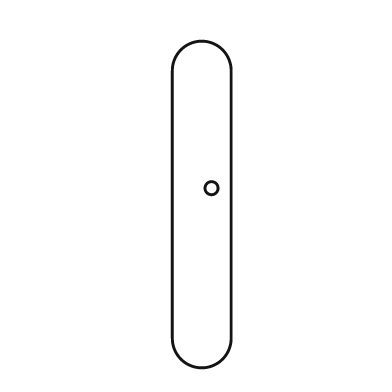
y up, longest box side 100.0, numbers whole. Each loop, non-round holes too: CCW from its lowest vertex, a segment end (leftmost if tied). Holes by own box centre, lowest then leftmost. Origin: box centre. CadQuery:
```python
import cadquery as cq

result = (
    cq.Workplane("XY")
    .moveTo(-9.0, -41.0)
    .threePointArc((0.0, -50.0), (9.0, -41.0))
    .lineTo(9.0, 41.0)
    .threePointArc((0.0, 50.0), (-9.0, 41.0))
    .close()
    .moveTo(3.0, 5.0)
    .circle(2.0)
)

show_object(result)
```